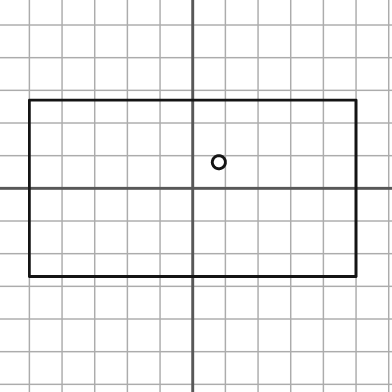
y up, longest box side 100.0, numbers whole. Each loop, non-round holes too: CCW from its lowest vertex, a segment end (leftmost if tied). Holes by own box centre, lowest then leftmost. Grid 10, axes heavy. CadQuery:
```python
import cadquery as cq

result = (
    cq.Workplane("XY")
    .moveTo(-50.0, -27.0)
    .lineTo(50.0, -27.0)
    .lineTo(50.0, 27.0)
    .lineTo(-50.0, 27.0)
    .close()
    .moveTo(8.0, 8.0)
    .circle(2.0)
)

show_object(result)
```